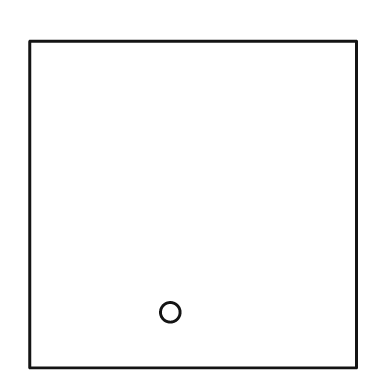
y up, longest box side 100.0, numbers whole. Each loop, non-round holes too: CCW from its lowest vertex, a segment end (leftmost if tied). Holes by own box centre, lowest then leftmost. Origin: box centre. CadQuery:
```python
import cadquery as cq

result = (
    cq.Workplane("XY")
    .moveTo(-50.0, -50.0)
    .lineTo(50.0, -50.0)
    .lineTo(50.0, 50.0)
    .lineTo(-50.0, 50.0)
    .close()
    .moveTo(-7.0, -33.0)
    .circle(3.0)
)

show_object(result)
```